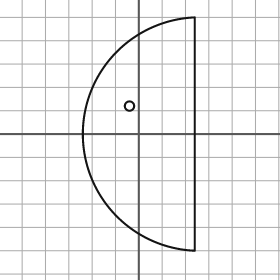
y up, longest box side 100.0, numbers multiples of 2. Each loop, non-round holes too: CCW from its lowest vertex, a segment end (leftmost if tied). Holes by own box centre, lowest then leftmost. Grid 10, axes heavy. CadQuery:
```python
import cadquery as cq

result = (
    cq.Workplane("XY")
    .moveTo(24.0, -50.0)
    .lineTo(24.0, 50.0)
    .threePointArc((-24.0, 0.0), (24.0, -50.0))
    .close()
    .moveTo(-4.0, 12.0)
    .circle(2.0)
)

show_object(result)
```